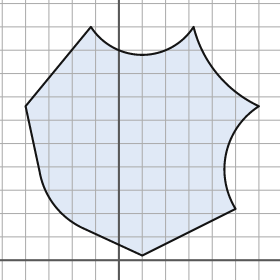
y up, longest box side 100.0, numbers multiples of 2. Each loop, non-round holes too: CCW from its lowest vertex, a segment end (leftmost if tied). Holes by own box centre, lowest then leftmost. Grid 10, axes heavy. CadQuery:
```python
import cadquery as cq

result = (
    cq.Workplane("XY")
    .moveTo(10.0, 2.0)
    .lineTo(50.0, 22.0)
    .threePointArc((46.0, 46.0), (60.0, 66.0))
    .threePointArc((42.0, 80.0), (32.0, 100.0))
    .threePointArc((10.0, 88.0), (-12.0, 100.0))
    .lineTo(-40.0, 66.0)
    .lineTo(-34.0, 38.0)
    .threePointArc((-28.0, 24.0), (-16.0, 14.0))
    .close()
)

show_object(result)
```